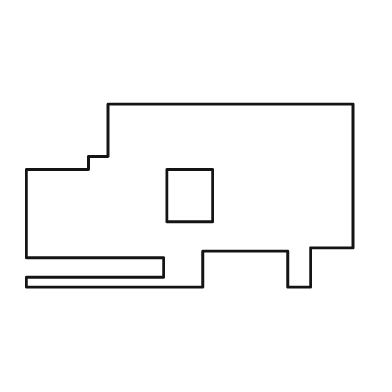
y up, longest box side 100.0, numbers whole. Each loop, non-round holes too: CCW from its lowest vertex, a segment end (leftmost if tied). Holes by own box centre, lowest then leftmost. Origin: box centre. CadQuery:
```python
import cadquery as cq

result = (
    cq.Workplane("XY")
    .moveTo(-50.0, -28.0)
    .lineTo(4.0, -28.0)
    .lineTo(4.0, -17.0)
    .lineTo(30.0, -17.0)
    .lineTo(30.0, -28.0)
    .lineTo(37.0, -28.0)
    .lineTo(37.0, -16.0)
    .lineTo(50.0, -16.0)
    .lineTo(50.0, 28.0)
    .lineTo(-25.0, 28.0)
    .lineTo(-25.0, 12.0)
    .lineTo(-31.0, 12.0)
    .lineTo(-31.0, 8.0)
    .lineTo(-50.0, 8.0)
    .lineTo(-50.0, -19.0)
    .lineTo(-8.0, -19.0)
    .lineTo(-8.0, -25.0)
    .lineTo(-50.0, -25.0)
    .close()
    .moveTo(-7.0, -8.0)
    .lineTo(7.0, -8.0)
    .lineTo(7.0, 8.0)
    .lineTo(-7.0, 8.0)
    .close()
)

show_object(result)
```